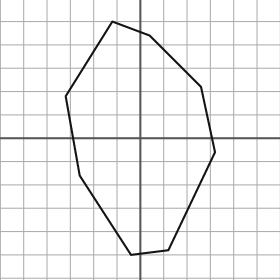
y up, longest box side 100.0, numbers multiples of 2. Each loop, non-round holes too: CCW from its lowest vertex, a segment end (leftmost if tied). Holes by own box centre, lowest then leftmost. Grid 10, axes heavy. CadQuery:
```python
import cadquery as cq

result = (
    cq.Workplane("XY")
    .moveTo(-4.0, -50.0)
    .lineTo(12.0, -48.0)
    .lineTo(32.0, -6.0)
    .lineTo(26.0, 22.0)
    .lineTo(4.0, 44.0)
    .lineTo(-12.0, 50.0)
    .lineTo(-32.0, 18.0)
    .lineTo(-26.0, -16.0)
    .close()
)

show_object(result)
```